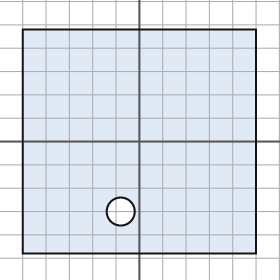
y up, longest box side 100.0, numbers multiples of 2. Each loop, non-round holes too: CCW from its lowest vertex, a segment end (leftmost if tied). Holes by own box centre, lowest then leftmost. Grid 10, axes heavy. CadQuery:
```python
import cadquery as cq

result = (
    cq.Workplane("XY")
    .moveTo(-50.0, -48.0)
    .lineTo(50.0, -48.0)
    .lineTo(50.0, 48.0)
    .lineTo(-50.0, 48.0)
    .close()
    .moveTo(-8.0, -30.0)
    .circle(6.0)
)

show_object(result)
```